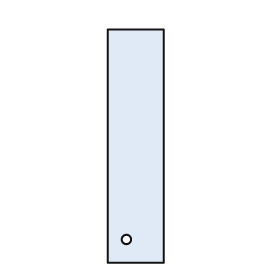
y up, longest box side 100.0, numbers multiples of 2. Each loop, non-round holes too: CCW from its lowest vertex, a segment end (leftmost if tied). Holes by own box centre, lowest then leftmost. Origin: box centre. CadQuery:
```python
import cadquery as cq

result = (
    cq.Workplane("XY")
    .moveTo(-12.0, -50.0)
    .lineTo(12.0, -50.0)
    .lineTo(12.0, 50.0)
    .lineTo(-12.0, 50.0)
    .close()
    .moveTo(-4.0, -40.0)
    .circle(2.0)
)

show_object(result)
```